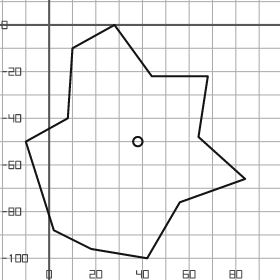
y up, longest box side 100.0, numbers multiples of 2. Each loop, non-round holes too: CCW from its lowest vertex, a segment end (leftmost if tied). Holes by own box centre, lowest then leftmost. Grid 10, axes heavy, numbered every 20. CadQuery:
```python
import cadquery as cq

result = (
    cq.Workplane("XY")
    .moveTo(42.0, -100.0)
    .lineTo(56.0, -76.0)
    .lineTo(84.0, -66.0)
    .lineTo(64.0, -48.0)
    .lineTo(68.0, -22.0)
    .lineTo(44.0, -22.0)
    .lineTo(28.0, 0.0)
    .lineTo(10.0, -10.0)
    .lineTo(8.0, -40.0)
    .lineTo(-10.0, -50.0)
    .lineTo(2.0, -88.0)
    .lineTo(18.0, -96.0)
    .close()
    .moveTo(38.0, -50.0)
    .circle(2.0)
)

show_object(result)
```